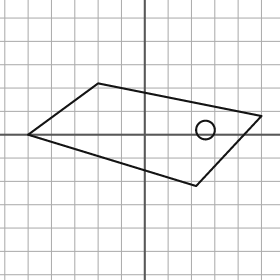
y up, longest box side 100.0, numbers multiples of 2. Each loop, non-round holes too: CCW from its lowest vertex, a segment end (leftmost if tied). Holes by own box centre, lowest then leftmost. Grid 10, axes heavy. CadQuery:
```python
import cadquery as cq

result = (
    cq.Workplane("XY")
    .moveTo(22.0, -22.0)
    .lineTo(50.0, 8.0)
    .lineTo(-20.0, 22.0)
    .lineTo(-50.0, 0.0)
    .close()
    .moveTo(26.0, 2.0)
    .circle(4.0)
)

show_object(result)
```